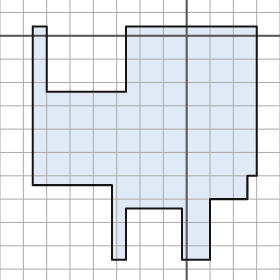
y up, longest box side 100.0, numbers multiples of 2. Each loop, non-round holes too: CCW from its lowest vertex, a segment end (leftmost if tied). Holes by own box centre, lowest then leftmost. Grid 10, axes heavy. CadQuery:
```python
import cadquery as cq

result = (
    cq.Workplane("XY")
    .moveTo(-32.0, -96.0)
    .lineTo(-26.0, -96.0)
    .lineTo(-26.0, -74.0)
    .lineTo(-2.0, -74.0)
    .lineTo(-2.0, -96.0)
    .lineTo(10.0, -96.0)
    .lineTo(10.0, -70.0)
    .lineTo(26.0, -70.0)
    .lineTo(26.0, -60.0)
    .lineTo(30.0, -60.0)
    .lineTo(30.0, 4.0)
    .lineTo(-26.0, 4.0)
    .lineTo(-26.0, -24.0)
    .lineTo(-60.0, -24.0)
    .lineTo(-60.0, 4.0)
    .lineTo(-66.0, 4.0)
    .lineTo(-66.0, -64.0)
    .lineTo(-32.0, -64.0)
    .close()
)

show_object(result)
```